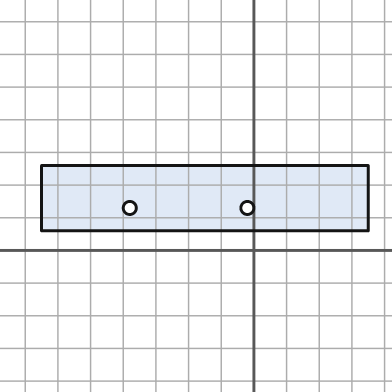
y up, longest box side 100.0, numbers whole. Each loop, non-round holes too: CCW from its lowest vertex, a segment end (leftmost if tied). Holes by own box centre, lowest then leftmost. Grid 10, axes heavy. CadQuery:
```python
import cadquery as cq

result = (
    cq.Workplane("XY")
    .moveTo(-65.0, 6.0)
    .lineTo(35.0, 6.0)
    .lineTo(35.0, 26.0)
    .lineTo(-65.0, 26.0)
    .close()
    .moveTo(-38.0, 13.0)
    .circle(2.0)
    .moveTo(-2.0, 13.0)
    .circle(2.0)
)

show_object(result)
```